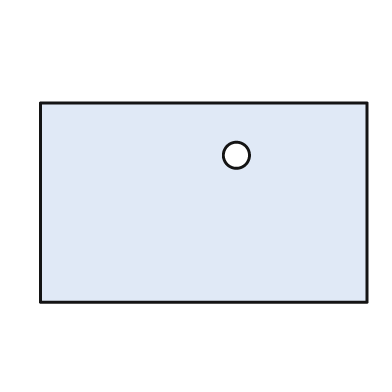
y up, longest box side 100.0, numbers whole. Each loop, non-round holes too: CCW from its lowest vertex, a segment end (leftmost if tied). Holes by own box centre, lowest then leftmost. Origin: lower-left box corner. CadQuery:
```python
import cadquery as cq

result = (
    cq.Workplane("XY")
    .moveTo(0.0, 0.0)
    .lineTo(100.0, 0.0)
    .lineTo(100.0, 61.0)
    .lineTo(0.0, 61.0)
    .close()
    .moveTo(60.0, 45.0)
    .circle(4.0)
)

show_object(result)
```